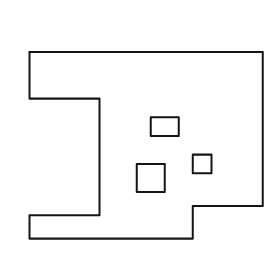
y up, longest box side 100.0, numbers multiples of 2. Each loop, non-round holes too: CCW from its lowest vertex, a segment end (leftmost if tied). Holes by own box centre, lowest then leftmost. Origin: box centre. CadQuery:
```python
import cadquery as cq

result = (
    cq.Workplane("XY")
    .moveTo(-50.0, -40.0)
    .lineTo(20.0, -40.0)
    .lineTo(20.0, -26.0)
    .lineTo(50.0, -26.0)
    .lineTo(50.0, 40.0)
    .lineTo(-50.0, 40.0)
    .lineTo(-50.0, 20.0)
    .lineTo(-20.0, 20.0)
    .lineTo(-20.0, -30.0)
    .lineTo(-50.0, -30.0)
    .close()
    .moveTo(-4.0, -20.0)
    .lineTo(8.0, -20.0)
    .lineTo(8.0, -8.0)
    .lineTo(-4.0, -8.0)
    .close()
    .moveTo(20.0, -12.0)
    .lineTo(28.0, -12.0)
    .lineTo(28.0, -4.0)
    .lineTo(20.0, -4.0)
    .close()
    .moveTo(2.0, 4.0)
    .lineTo(14.0, 4.0)
    .lineTo(14.0, 12.0)
    .lineTo(2.0, 12.0)
    .close()
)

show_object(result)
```